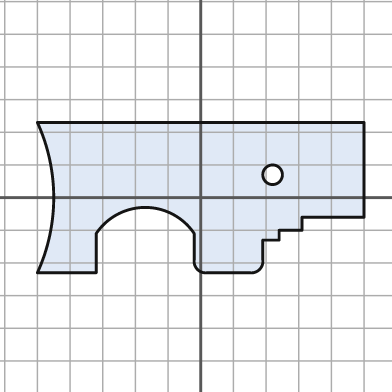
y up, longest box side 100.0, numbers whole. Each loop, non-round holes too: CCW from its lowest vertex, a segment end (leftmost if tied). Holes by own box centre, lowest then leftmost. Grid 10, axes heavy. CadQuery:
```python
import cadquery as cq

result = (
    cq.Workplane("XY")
    .moveTo(-50.0, -23.0)
    .lineTo(-32.0, -23.0)
    .lineTo(-32.0, -11.0)
    .threePointArc((-17.0, -3.0), (-2.0, -11.0))
    .lineTo(-2.0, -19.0)
    .threePointArc((-1.0, -22.0), (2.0, -23.0))
    .lineTo(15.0, -23.0)
    .threePointArc((18.0, -22.0), (19.0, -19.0))
    .lineTo(19.0, -13.0)
    .lineTo(24.0, -13.0)
    .lineTo(24.0, -10.0)
    .lineTo(31.0, -10.0)
    .lineTo(31.0, -6.0)
    .lineTo(50.0, -6.0)
    .lineTo(50.0, 23.0)
    .lineTo(-50.0, 23.0)
    .threePointArc((-45.0, 0.0), (-50.0, -23.0))
    .close()
    .moveTo(22.0, 7.0)
    .circle(3.0)
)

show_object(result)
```